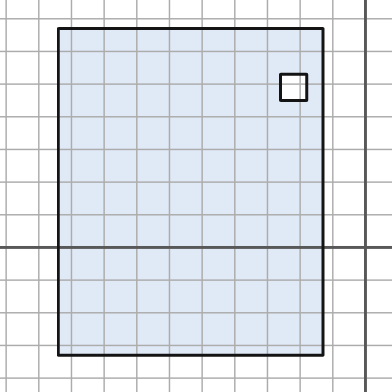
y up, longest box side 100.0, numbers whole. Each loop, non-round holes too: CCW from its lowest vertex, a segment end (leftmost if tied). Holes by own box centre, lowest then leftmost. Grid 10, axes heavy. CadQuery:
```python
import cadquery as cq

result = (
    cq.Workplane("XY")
    .moveTo(-94.0, -33.0)
    .lineTo(-13.0, -33.0)
    .lineTo(-13.0, 67.0)
    .lineTo(-94.0, 67.0)
    .close()
    .moveTo(-26.0, 45.0)
    .lineTo(-18.0, 45.0)
    .lineTo(-18.0, 53.0)
    .lineTo(-26.0, 53.0)
    .close()
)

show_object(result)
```